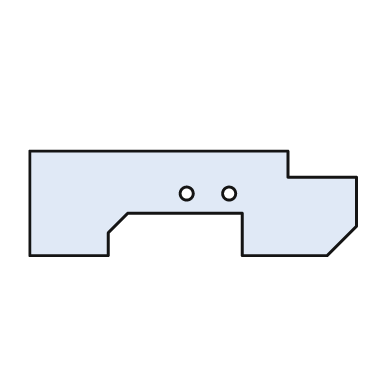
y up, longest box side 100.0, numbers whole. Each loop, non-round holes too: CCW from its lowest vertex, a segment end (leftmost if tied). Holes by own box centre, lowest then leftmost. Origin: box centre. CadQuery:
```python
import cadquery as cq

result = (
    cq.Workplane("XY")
    .moveTo(-50.0, -16.0)
    .lineTo(-26.0, -16.0)
    .lineTo(-26.0, -9.0)
    .lineTo(-20.0, -3.0)
    .lineTo(15.0, -3.0)
    .lineTo(15.0, -16.0)
    .lineTo(41.0, -16.0)
    .lineTo(50.0, -7.0)
    .lineTo(50.0, 8.0)
    .lineTo(29.0, 8.0)
    .lineTo(29.0, 16.0)
    .lineTo(-50.0, 16.0)
    .close()
    .moveTo(-2.0, 3.0)
    .circle(2.0)
    .moveTo(11.0, 3.0)
    .circle(2.0)
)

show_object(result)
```